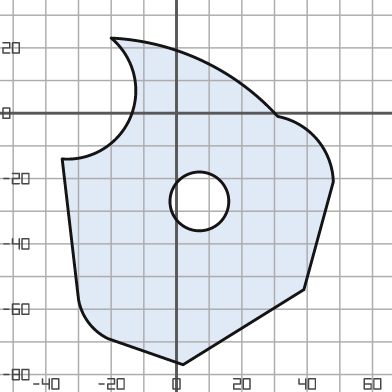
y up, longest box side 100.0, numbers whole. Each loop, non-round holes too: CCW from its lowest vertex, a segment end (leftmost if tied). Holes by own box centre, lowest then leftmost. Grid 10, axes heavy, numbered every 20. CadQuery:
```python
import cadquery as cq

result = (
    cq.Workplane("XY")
    .moveTo(2.0, -77.0)
    .lineTo(39.0, -54.0)
    .lineTo(48.0, -21.0)
    .threePointArc((43.0, -8.0), (31.0, -1.0))
    .threePointArc((8.0, 16.0), (-20.0, 23.0))
    .threePointArc((-14.0, -1.0), (-35.0, -14.0))
    .lineTo(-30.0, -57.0)
    .threePointArc((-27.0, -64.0), (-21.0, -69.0))
    .close()
    .moveTo(7.0, -27.0)
    .circle(9.0)
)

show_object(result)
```